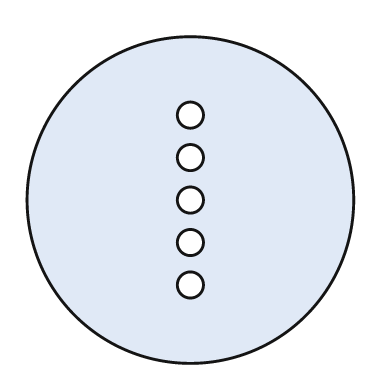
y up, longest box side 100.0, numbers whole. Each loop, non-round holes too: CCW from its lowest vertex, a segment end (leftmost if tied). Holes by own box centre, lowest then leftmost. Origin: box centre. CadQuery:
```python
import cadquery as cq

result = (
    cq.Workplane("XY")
    .moveTo(0.0, 0.0)
    .circle(50.0)
    .moveTo(0.0, -26.0)
    .circle(4.0)
    .moveTo(0.0, -13.0)
    .circle(4.0)
    .moveTo(0.0, 0.0)
    .circle(4.0)
    .moveTo(0.0, 13.0)
    .circle(4.0)
    .moveTo(0.0, 26.0)
    .circle(4.0)
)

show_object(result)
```